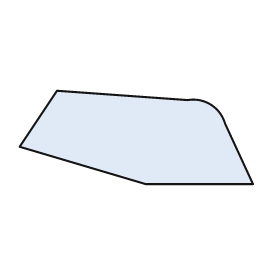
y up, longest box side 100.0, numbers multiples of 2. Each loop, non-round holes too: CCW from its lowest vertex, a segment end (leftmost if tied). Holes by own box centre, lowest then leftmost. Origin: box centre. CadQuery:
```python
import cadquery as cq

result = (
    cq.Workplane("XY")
    .moveTo(4.0, -20.0)
    .lineTo(50.0, -20.0)
    .lineTo(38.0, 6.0)
    .threePointArc((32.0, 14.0), (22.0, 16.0))
    .lineTo(-34.0, 20.0)
    .lineTo(-50.0, -4.0)
    .close()
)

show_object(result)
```